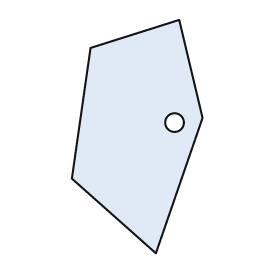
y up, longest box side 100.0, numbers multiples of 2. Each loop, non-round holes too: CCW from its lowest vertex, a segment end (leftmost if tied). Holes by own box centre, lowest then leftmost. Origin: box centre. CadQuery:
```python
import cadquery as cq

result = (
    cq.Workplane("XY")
    .moveTo(8.0, -50.0)
    .lineTo(28.0, 8.0)
    .lineTo(18.0, 50.0)
    .lineTo(-20.0, 38.0)
    .lineTo(-28.0, -18.0)
    .close()
    .moveTo(16.0, 6.0)
    .circle(4.0)
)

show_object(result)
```